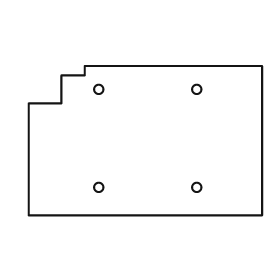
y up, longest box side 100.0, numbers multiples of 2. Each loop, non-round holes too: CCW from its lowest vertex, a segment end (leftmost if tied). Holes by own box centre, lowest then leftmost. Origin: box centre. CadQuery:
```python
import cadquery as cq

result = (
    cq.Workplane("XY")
    .moveTo(-50.0, -32.0)
    .lineTo(50.0, -32.0)
    .lineTo(50.0, 32.0)
    .lineTo(-26.0, 32.0)
    .lineTo(-26.0, 28.0)
    .lineTo(-36.0, 28.0)
    .lineTo(-36.0, 16.0)
    .lineTo(-50.0, 16.0)
    .close()
    .moveTo(-20.0, -20.0)
    .circle(2.0)
    .moveTo(22.0, -20.0)
    .circle(2.0)
    .moveTo(-20.0, 22.0)
    .circle(2.0)
    .moveTo(22.0, 22.0)
    .circle(2.0)
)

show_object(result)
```